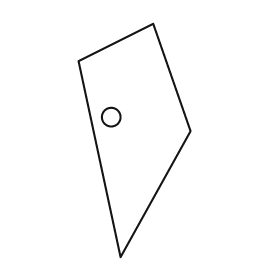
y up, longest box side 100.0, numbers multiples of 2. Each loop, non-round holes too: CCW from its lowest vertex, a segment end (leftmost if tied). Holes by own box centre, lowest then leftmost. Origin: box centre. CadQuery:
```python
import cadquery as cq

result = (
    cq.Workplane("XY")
    .moveTo(-6.0, -50.0)
    .lineTo(24.0, 4.0)
    .lineTo(8.0, 50.0)
    .lineTo(-24.0, 34.0)
    .close()
    .moveTo(-10.0, 10.0)
    .circle(4.0)
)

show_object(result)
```